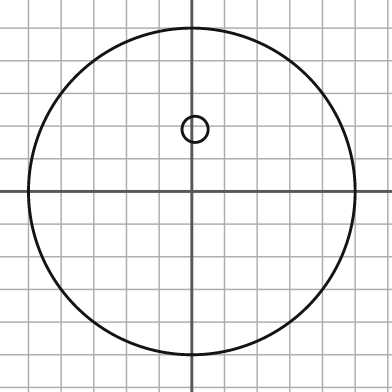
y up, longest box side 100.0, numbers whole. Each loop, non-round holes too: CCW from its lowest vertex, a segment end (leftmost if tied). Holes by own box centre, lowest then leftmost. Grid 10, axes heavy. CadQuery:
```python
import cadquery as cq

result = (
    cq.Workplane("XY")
    .moveTo(0.0, 0.0)
    .circle(50.0)
    .moveTo(1.0, 19.0)
    .circle(4.0)
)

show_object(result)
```